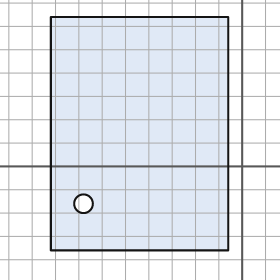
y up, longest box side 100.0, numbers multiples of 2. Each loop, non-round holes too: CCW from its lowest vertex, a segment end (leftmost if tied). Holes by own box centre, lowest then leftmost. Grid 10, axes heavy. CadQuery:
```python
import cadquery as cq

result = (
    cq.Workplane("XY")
    .moveTo(-82.0, -36.0)
    .lineTo(-6.0, -36.0)
    .lineTo(-6.0, 64.0)
    .lineTo(-82.0, 64.0)
    .close()
    .moveTo(-68.0, -16.0)
    .circle(4.0)
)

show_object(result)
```